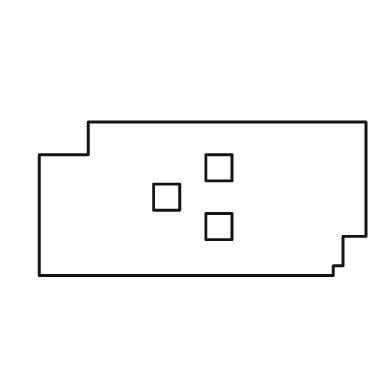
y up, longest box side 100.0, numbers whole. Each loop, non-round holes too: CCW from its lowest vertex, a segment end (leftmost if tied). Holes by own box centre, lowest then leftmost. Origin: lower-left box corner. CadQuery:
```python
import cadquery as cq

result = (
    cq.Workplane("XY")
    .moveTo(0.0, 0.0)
    .lineTo(90.0, 0.0)
    .lineTo(90.0, 3.0)
    .lineTo(93.0, 3.0)
    .lineTo(93.0, 12.0)
    .lineTo(100.0, 12.0)
    .lineTo(100.0, 47.0)
    .lineTo(15.0, 47.0)
    .lineTo(15.0, 37.0)
    .lineTo(0.0, 37.0)
    .close()
    .moveTo(51.0, 11.0)
    .lineTo(59.0, 11.0)
    .lineTo(59.0, 19.0)
    .lineTo(51.0, 19.0)
    .close()
    .moveTo(35.0, 20.0)
    .lineTo(43.0, 20.0)
    .lineTo(43.0, 28.0)
    .lineTo(35.0, 28.0)
    .close()
    .moveTo(51.0, 29.0)
    .lineTo(59.0, 29.0)
    .lineTo(59.0, 37.0)
    .lineTo(51.0, 37.0)
    .close()
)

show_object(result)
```